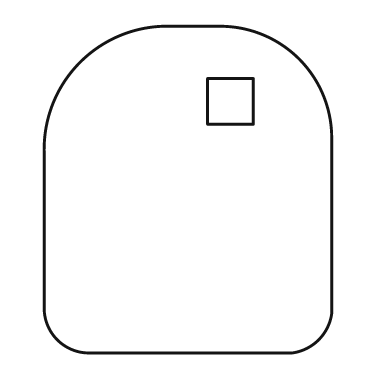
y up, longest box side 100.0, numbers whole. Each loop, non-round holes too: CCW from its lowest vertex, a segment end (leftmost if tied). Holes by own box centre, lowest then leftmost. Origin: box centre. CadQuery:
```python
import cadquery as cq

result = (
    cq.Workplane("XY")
    .moveTo(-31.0, -50.0)
    .lineTo(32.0, -50.0)
    .threePointArc((40.0, -46.0), (44.0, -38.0))
    .lineTo(44.0, 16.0)
    .threePointArc((34.0, 40.0), (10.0, 50.0))
    .lineTo(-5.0, 50.0)
    .threePointArc((-33.0, 39.0), (-44.0, 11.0))
    .lineTo(-44.0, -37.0)
    .threePointArc((-40.0, -46.0), (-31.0, -50.0))
    .close()
    .moveTo(6.0, 20.0)
    .lineTo(20.0, 20.0)
    .lineTo(20.0, 34.0)
    .lineTo(6.0, 34.0)
    .close()
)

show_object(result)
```